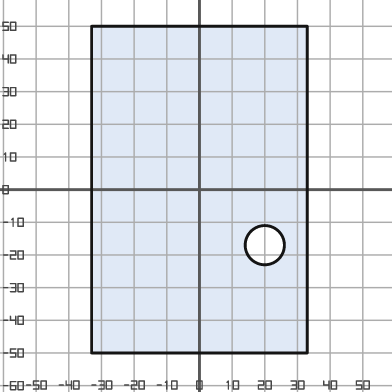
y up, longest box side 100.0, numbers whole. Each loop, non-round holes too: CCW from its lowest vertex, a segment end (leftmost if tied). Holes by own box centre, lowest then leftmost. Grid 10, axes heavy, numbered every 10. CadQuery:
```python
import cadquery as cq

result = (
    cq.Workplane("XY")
    .moveTo(-33.0, -50.0)
    .lineTo(33.0, -50.0)
    .lineTo(33.0, 50.0)
    .lineTo(-33.0, 50.0)
    .close()
    .moveTo(20.0, -17.0)
    .circle(6.0)
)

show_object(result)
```